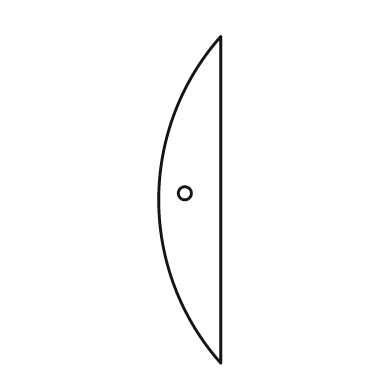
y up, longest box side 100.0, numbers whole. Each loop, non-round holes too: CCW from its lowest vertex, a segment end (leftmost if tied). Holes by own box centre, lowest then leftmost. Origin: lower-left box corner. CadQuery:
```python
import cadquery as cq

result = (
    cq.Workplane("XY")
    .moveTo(19.0, 0.0)
    .lineTo(19.0, 100.0)
    .threePointArc((0.0, 50.0), (19.0, 0.0))
    .close()
    .moveTo(8.0, 52.0)
    .circle(2.0)
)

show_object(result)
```